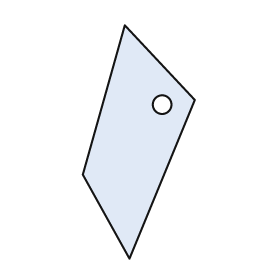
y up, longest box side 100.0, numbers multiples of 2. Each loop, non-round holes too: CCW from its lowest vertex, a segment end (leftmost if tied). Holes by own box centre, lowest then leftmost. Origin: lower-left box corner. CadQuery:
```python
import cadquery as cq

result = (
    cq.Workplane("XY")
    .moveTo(20.0, 0.0)
    .lineTo(48.0, 68.0)
    .lineTo(18.0, 100.0)
    .lineTo(0.0, 36.0)
    .close()
    .moveTo(34.0, 66.0)
    .circle(4.0)
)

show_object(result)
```